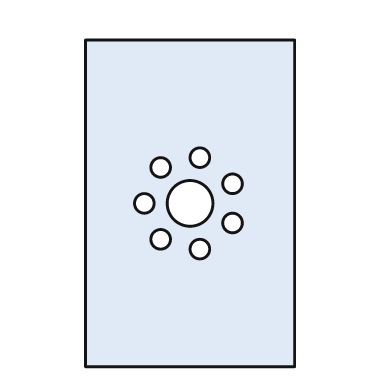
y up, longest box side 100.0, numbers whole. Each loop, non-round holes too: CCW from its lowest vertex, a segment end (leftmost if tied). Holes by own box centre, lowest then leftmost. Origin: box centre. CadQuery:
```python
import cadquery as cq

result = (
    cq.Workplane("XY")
    .moveTo(-32.0, -50.0)
    .lineTo(32.0, -50.0)
    .lineTo(32.0, 50.0)
    .lineTo(-32.0, 50.0)
    .close()
    .moveTo(3.0, -14.0)
    .circle(3.0)
    .moveTo(-9.0, -11.0)
    .circle(3.0)
    .moveTo(13.0, -6.0)
    .circle(3.0)
    .moveTo(-14.0, 0.0)
    .circle(3.0)
    .moveTo(0.0, 0.0)
    .circle(7.0)
    .moveTo(13.0, 6.0)
    .circle(3.0)
    .moveTo(-9.0, 11.0)
    .circle(3.0)
    .moveTo(3.0, 14.0)
    .circle(3.0)
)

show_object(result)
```